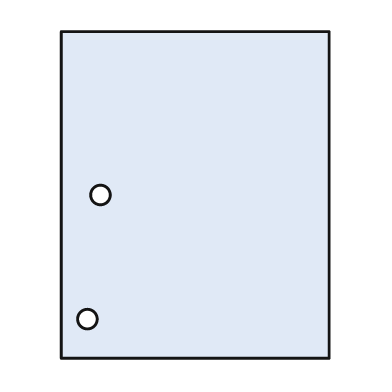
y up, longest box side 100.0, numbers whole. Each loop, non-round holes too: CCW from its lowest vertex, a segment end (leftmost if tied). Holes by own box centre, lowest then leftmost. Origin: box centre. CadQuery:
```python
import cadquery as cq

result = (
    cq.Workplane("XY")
    .moveTo(-41.0, -50.0)
    .lineTo(41.0, -50.0)
    .lineTo(41.0, 50.0)
    .lineTo(-41.0, 50.0)
    .close()
    .moveTo(-33.0, -38.0)
    .circle(3.0)
    .moveTo(-29.0, 0.0)
    .circle(3.0)
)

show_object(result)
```